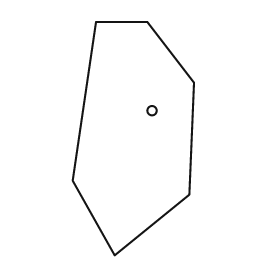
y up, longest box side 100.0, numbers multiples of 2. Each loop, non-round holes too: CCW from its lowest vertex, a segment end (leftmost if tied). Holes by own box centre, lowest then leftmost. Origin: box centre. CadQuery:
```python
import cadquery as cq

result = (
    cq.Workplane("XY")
    .moveTo(-8.0, -50.0)
    .lineTo(24.0, -24.0)
    .lineTo(26.0, 24.0)
    .lineTo(6.0, 50.0)
    .lineTo(-16.0, 50.0)
    .lineTo(-26.0, -18.0)
    .close()
    .moveTo(8.0, 12.0)
    .circle(2.0)
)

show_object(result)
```